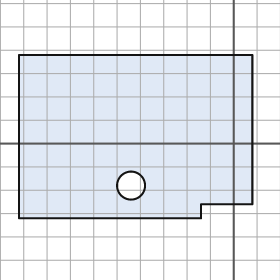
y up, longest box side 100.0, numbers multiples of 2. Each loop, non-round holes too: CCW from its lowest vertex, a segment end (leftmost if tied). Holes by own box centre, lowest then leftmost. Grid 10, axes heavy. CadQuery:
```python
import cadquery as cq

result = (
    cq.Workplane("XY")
    .moveTo(-92.0, -32.0)
    .lineTo(-14.0, -32.0)
    .lineTo(-14.0, -26.0)
    .lineTo(8.0, -26.0)
    .lineTo(8.0, 38.0)
    .lineTo(-92.0, 38.0)
    .close()
    .moveTo(-44.0, -18.0)
    .circle(6.0)
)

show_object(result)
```